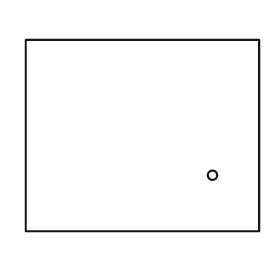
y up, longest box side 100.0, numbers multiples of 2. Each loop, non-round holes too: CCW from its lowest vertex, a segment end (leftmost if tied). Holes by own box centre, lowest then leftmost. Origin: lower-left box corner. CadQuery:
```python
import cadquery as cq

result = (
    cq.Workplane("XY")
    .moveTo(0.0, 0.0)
    .lineTo(100.0, 0.0)
    .lineTo(100.0, 82.0)
    .lineTo(0.0, 82.0)
    .close()
    .moveTo(80.0, 24.0)
    .circle(2.0)
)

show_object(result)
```